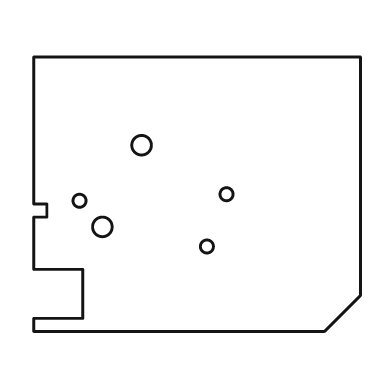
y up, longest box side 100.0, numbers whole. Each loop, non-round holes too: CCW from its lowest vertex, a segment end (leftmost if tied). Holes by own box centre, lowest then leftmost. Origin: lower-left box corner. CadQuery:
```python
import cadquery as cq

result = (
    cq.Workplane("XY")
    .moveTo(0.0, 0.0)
    .lineTo(89.0, 0.0)
    .lineTo(100.0, 11.0)
    .lineTo(100.0, 84.0)
    .lineTo(0.0, 84.0)
    .lineTo(0.0, 39.0)
    .lineTo(4.0, 39.0)
    .lineTo(4.0, 35.0)
    .lineTo(0.0, 35.0)
    .lineTo(0.0, 19.0)
    .lineTo(15.0, 19.0)
    .lineTo(15.0, 4.0)
    .lineTo(0.0, 4.0)
    .close()
    .moveTo(53.0, 26.0)
    .circle(2.0)
    .moveTo(21.0, 32.0)
    .circle(3.0)
    .moveTo(14.0, 40.0)
    .circle(2.0)
    .moveTo(59.0, 42.0)
    .circle(2.0)
    .moveTo(33.0, 57.0)
    .circle(3.0)
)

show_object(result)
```